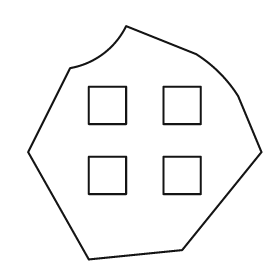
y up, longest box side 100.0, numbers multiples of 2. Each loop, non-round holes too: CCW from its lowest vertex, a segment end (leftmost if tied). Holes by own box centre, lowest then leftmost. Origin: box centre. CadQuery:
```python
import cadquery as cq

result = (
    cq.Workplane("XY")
    .moveTo(-24.0, -50.0)
    .lineTo(16.0, -46.0)
    .lineTo(50.0, -4.0)
    .lineTo(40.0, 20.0)
    .threePointArc((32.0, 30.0), (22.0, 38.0))
    .lineTo(-8.0, 50.0)
    .threePointArc((-18.0, 38.0), (-32.0, 32.0))
    .lineTo(-50.0, -4.0)
    .close()
    .moveTo(-24.0, -22.0)
    .lineTo(-8.0, -22.0)
    .lineTo(-8.0, -6.0)
    .lineTo(-24.0, -6.0)
    .close()
    .moveTo(8.0, -22.0)
    .lineTo(24.0, -22.0)
    .lineTo(24.0, -6.0)
    .lineTo(8.0, -6.0)
    .close()
    .moveTo(-24.0, 8.0)
    .lineTo(-8.0, 8.0)
    .lineTo(-8.0, 24.0)
    .lineTo(-24.0, 24.0)
    .close()
    .moveTo(8.0, 8.0)
    .lineTo(24.0, 8.0)
    .lineTo(24.0, 24.0)
    .lineTo(8.0, 24.0)
    .close()
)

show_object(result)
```